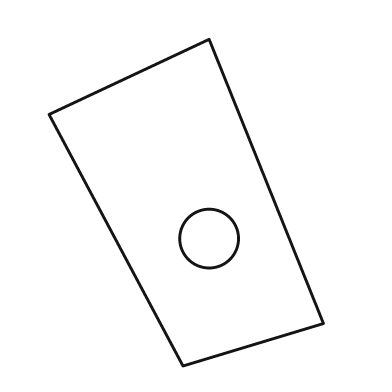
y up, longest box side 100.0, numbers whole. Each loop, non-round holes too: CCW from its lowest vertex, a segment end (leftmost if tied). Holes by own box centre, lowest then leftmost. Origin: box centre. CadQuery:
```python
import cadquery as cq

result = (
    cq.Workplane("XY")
    .moveTo(-1.0, -50.0)
    .lineTo(42.0, -37.0)
    .lineTo(7.0, 50.0)
    .lineTo(-42.0, 27.0)
    .close()
    .moveTo(7.0, -11.0)
    .circle(9.0)
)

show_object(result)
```